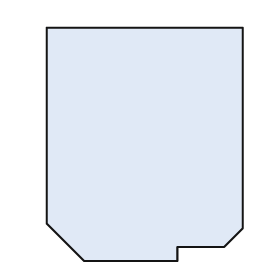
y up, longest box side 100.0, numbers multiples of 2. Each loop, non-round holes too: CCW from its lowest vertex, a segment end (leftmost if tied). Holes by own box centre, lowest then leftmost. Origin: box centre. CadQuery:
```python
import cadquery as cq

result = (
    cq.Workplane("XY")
    .moveTo(-26.0, -50.0)
    .lineTo(14.0, -50.0)
    .lineTo(14.0, -44.0)
    .lineTo(34.0, -44.0)
    .lineTo(42.0, -36.0)
    .lineTo(42.0, 50.0)
    .lineTo(-42.0, 50.0)
    .lineTo(-42.0, -34.0)
    .close()
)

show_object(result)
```